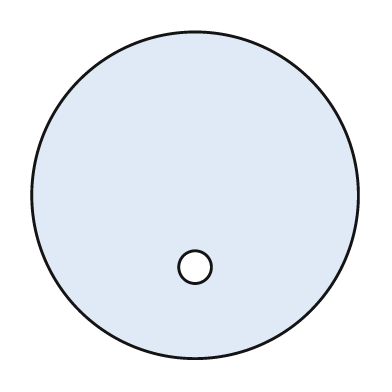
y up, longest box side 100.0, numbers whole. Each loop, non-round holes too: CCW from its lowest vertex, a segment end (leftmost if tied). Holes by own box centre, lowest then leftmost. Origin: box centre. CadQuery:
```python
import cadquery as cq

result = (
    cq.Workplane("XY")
    .moveTo(0.0, 0.0)
    .circle(50.0)
    .moveTo(0.0, -22.0)
    .circle(5.0)
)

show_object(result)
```